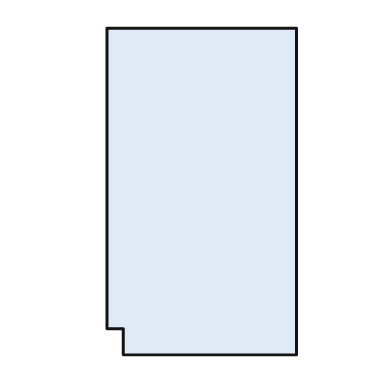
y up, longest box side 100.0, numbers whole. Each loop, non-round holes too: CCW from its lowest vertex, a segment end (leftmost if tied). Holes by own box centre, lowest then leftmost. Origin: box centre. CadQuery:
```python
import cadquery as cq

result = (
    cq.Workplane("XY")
    .moveTo(-24.0, -50.0)
    .lineTo(29.0, -50.0)
    .lineTo(29.0, 50.0)
    .lineTo(-29.0, 50.0)
    .lineTo(-29.0, -42.0)
    .lineTo(-24.0, -42.0)
    .close()
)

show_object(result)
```